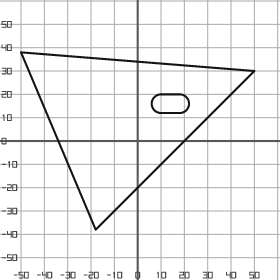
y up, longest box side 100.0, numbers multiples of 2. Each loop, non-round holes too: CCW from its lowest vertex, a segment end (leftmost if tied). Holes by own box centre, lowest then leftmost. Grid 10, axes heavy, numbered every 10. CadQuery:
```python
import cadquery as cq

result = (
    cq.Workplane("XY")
    .moveTo(-18.0, -38.0)
    .lineTo(50.0, 30.0)
    .lineTo(-50.0, 38.0)
    .close()
    .moveTo(10.0, 12.0)
    .lineTo(18.0, 12.0)
    .threePointArc((22.0, 16.0), (18.0, 20.0))
    .lineTo(10.0, 20.0)
    .threePointArc((6.0, 16.0), (10.0, 12.0))
    .close()
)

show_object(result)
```